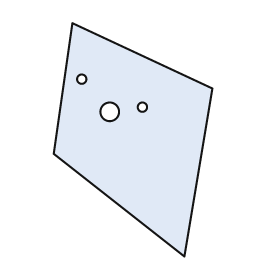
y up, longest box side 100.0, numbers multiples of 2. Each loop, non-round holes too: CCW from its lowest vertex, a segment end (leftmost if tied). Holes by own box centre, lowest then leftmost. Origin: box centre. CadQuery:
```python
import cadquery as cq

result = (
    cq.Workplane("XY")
    .moveTo(22.0, -50.0)
    .lineTo(34.0, 22.0)
    .lineTo(-26.0, 50.0)
    .lineTo(-34.0, -6.0)
    .close()
    .moveTo(-10.0, 12.0)
    .circle(4.0)
    .moveTo(4.0, 14.0)
    .circle(2.0)
    .moveTo(-22.0, 26.0)
    .circle(2.0)
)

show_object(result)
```